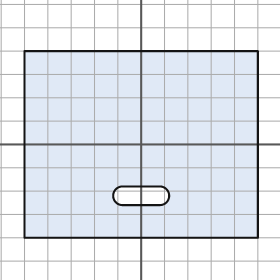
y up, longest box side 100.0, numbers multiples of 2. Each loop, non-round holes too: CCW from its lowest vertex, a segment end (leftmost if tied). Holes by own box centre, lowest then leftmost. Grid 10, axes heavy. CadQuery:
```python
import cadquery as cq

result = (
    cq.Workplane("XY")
    .moveTo(-50.0, -40.0)
    .lineTo(50.0, -40.0)
    .lineTo(50.0, 40.0)
    .lineTo(-50.0, 40.0)
    .close()
    .moveTo(-8.0, -26.0)
    .lineTo(8.0, -26.0)
    .threePointArc((12.0, -22.0), (8.0, -18.0))
    .lineTo(-8.0, -18.0)
    .threePointArc((-12.0, -22.0), (-8.0, -26.0))
    .close()
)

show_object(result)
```